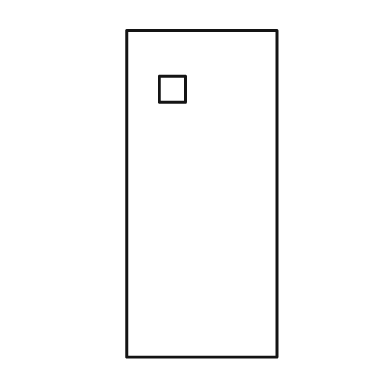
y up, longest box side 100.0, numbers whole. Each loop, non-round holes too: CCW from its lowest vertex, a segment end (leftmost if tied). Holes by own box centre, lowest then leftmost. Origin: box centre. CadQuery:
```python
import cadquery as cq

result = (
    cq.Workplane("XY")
    .moveTo(-23.0, -50.0)
    .lineTo(23.0, -50.0)
    .lineTo(23.0, 50.0)
    .lineTo(-23.0, 50.0)
    .close()
    .moveTo(-13.0, 28.0)
    .lineTo(-5.0, 28.0)
    .lineTo(-5.0, 36.0)
    .lineTo(-13.0, 36.0)
    .close()
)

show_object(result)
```